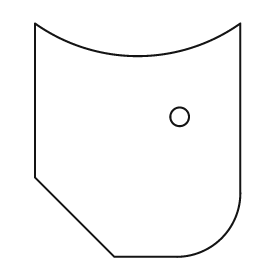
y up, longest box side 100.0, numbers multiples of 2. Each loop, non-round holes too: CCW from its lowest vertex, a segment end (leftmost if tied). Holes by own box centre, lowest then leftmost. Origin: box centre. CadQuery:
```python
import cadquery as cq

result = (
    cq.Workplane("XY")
    .moveTo(-10.0, -50.0)
    .lineTo(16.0, -50.0)
    .threePointArc((36.0, -42.0), (44.0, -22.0))
    .lineTo(44.0, 50.0)
    .threePointArc((0.0, 36.0), (-44.0, 50.0))
    .lineTo(-44.0, -16.0)
    .close()
    .moveTo(18.0, 10.0)
    .circle(4.0)
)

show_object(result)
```